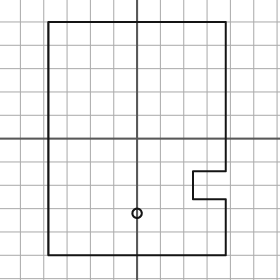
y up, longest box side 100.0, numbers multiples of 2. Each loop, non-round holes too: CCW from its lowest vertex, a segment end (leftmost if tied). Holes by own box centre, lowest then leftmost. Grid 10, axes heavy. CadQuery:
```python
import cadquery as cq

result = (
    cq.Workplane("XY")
    .moveTo(-38.0, -50.0)
    .lineTo(38.0, -50.0)
    .lineTo(38.0, -26.0)
    .lineTo(24.0, -26.0)
    .lineTo(24.0, -14.0)
    .lineTo(38.0, -14.0)
    .lineTo(38.0, 50.0)
    .lineTo(-38.0, 50.0)
    .close()
    .moveTo(0.0, -32.0)
    .circle(2.0)
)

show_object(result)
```